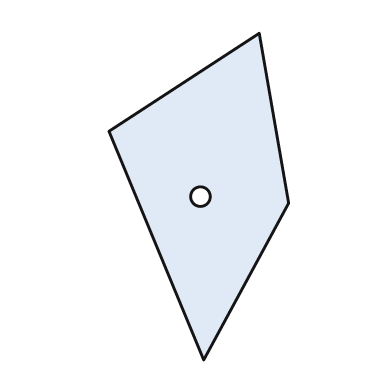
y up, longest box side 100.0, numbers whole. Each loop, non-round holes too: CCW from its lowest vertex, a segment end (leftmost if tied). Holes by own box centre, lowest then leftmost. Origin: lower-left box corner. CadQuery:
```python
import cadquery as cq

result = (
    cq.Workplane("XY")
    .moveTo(29.0, 0.0)
    .lineTo(55.0, 48.0)
    .lineTo(46.0, 100.0)
    .lineTo(0.0, 70.0)
    .close()
    .moveTo(28.0, 50.0)
    .circle(3.0)
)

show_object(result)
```